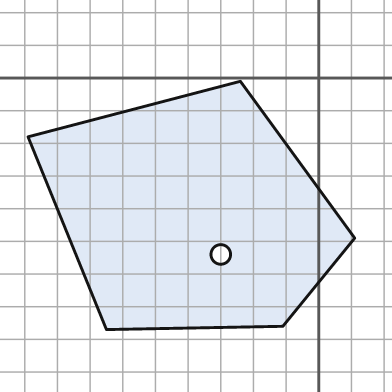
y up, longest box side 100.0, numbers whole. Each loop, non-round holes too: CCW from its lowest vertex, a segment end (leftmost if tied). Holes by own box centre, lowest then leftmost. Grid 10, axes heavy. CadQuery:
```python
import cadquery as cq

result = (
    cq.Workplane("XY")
    .moveTo(-65.0, -77.0)
    .lineTo(-11.0, -76.0)
    .lineTo(11.0, -49.0)
    .lineTo(-24.0, -1.0)
    .lineTo(-89.0, -18.0)
    .close()
    .moveTo(-30.0, -54.0)
    .circle(3.0)
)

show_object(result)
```